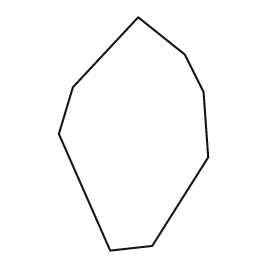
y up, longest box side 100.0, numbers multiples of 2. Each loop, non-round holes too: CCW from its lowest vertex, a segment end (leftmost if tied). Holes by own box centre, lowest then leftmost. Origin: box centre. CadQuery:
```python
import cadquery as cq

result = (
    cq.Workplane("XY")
    .moveTo(-10.0, -50.0)
    .lineTo(8.0, -48.0)
    .lineTo(32.0, -10.0)
    .lineTo(30.0, 18.0)
    .lineTo(22.0, 34.0)
    .lineTo(2.0, 50.0)
    .lineTo(-26.0, 20.0)
    .lineTo(-32.0, 0.0)
    .close()
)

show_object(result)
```